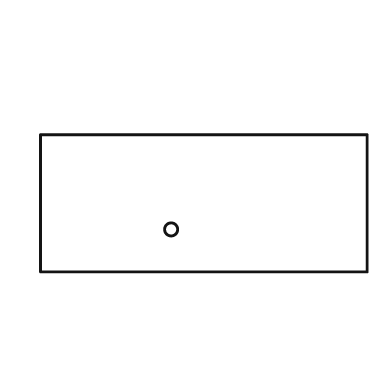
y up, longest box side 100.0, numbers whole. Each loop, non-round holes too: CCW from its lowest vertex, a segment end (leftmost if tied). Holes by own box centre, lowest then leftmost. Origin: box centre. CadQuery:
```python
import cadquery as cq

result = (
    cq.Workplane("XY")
    .moveTo(-50.0, -21.0)
    .lineTo(50.0, -21.0)
    .lineTo(50.0, 21.0)
    .lineTo(-50.0, 21.0)
    .close()
    .moveTo(-10.0, -8.0)
    .circle(2.0)
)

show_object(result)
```